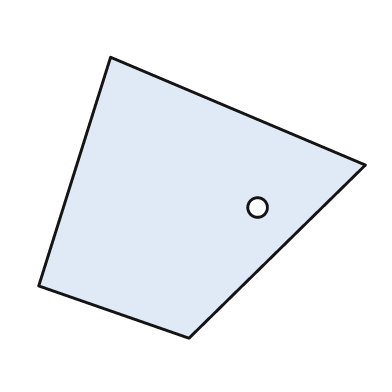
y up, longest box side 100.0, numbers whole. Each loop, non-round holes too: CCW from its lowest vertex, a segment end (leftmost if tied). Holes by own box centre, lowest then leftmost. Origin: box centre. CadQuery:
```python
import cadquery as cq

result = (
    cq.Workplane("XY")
    .moveTo(-4.0, -43.0)
    .lineTo(50.0, 10.0)
    .lineTo(-28.0, 43.0)
    .lineTo(-50.0, -27.0)
    .close()
    .moveTo(17.0, -3.0)
    .circle(3.0)
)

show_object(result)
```